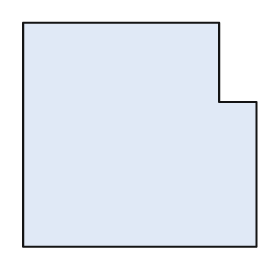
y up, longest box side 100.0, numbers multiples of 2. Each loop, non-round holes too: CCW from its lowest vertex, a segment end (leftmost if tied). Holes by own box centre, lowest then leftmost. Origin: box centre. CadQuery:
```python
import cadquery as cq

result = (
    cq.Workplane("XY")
    .moveTo(-50.0, -48.0)
    .lineTo(50.0, -48.0)
    .lineTo(50.0, 14.0)
    .lineTo(34.0, 14.0)
    .lineTo(34.0, 48.0)
    .lineTo(-50.0, 48.0)
    .close()
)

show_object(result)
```